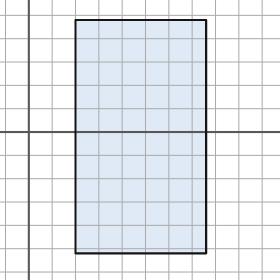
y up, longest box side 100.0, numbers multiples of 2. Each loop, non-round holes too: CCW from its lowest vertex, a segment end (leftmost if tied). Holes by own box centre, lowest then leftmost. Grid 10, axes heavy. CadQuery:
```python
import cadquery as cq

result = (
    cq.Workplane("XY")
    .moveTo(20.0, -52.0)
    .lineTo(76.0, -52.0)
    .lineTo(76.0, 48.0)
    .lineTo(20.0, 48.0)
    .close()
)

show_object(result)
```